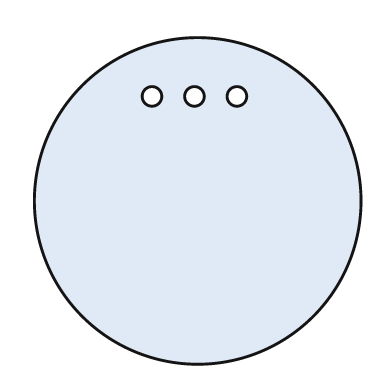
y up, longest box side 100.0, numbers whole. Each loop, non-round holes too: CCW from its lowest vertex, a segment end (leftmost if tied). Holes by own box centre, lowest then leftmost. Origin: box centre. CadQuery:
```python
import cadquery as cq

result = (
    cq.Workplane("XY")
    .moveTo(0.0, 0.0)
    .circle(50.0)
    .moveTo(-14.0, 32.0)
    .circle(3.0)
    .moveTo(-1.0, 32.0)
    .circle(3.0)
    .moveTo(12.0, 32.0)
    .circle(3.0)
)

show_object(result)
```